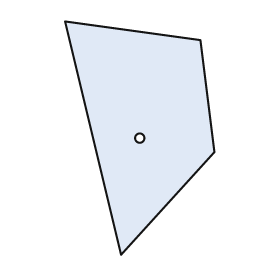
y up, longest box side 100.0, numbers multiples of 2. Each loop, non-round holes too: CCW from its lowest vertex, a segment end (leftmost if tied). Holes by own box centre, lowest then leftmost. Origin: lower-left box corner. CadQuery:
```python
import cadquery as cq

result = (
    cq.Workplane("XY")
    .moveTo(24.0, 0.0)
    .lineTo(64.0, 44.0)
    .lineTo(58.0, 92.0)
    .lineTo(0.0, 100.0)
    .close()
    .moveTo(32.0, 50.0)
    .circle(2.0)
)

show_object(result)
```